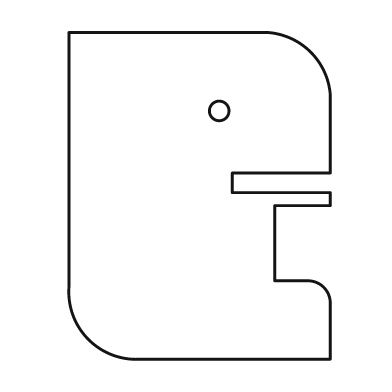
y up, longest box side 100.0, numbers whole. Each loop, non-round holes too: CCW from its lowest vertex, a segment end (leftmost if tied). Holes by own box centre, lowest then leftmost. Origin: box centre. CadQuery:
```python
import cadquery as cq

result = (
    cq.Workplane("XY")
    .moveTo(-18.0, -50.0)
    .lineTo(40.0, -50.0)
    .lineTo(40.0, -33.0)
    .threePointArc((38.0, -28.0), (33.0, -26.0))
    .lineTo(23.0, -26.0)
    .lineTo(23.0, -3.0)
    .lineTo(40.0, -3.0)
    .lineTo(40.0, 1.0)
    .lineTo(10.0, 1.0)
    .lineTo(10.0, 7.0)
    .lineTo(40.0, 7.0)
    .lineTo(40.0, 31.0)
    .threePointArc((34.0, 44.0), (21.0, 50.0))
    .lineTo(-40.0, 50.0)
    .lineTo(-40.0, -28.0)
    .threePointArc((-34.0, -44.0), (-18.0, -50.0))
    .close()
    .moveTo(6.0, 26.0)
    .circle(3.0)
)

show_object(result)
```